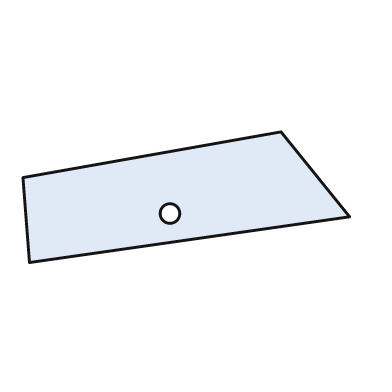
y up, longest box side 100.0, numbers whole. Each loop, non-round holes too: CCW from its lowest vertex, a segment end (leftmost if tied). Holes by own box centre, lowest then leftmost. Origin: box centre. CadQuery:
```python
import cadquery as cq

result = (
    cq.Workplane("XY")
    .moveTo(-48.0, -20.0)
    .lineTo(50.0, -6.0)
    .lineTo(29.0, 20.0)
    .lineTo(-50.0, 6.0)
    .close()
    .moveTo(-5.0, -5.0)
    .circle(3.0)
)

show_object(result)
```